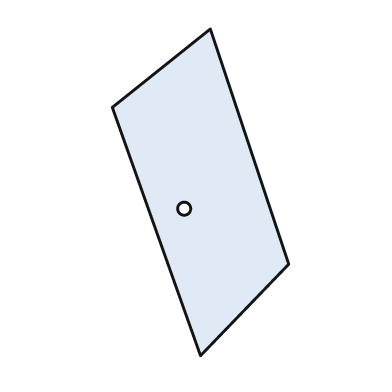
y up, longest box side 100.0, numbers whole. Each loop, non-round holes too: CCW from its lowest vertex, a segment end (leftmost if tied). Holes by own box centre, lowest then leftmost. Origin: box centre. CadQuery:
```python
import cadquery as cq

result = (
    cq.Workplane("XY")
    .moveTo(0.0, -50.0)
    .lineTo(27.0, -22.0)
    .lineTo(3.0, 50.0)
    .lineTo(-27.0, 26.0)
    .close()
    .moveTo(-5.0, -5.0)
    .circle(2.0)
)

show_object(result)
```